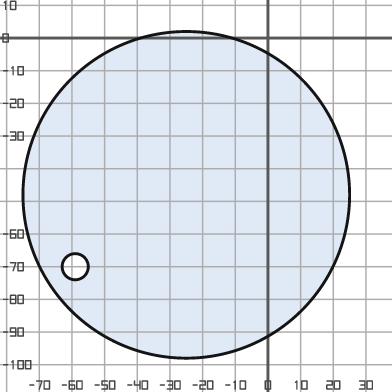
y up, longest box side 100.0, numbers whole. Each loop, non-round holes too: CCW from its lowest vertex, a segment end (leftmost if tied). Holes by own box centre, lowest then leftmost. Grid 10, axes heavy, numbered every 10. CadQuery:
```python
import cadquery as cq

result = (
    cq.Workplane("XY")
    .moveTo(-25.0, -48.0)
    .circle(50.0)
    .moveTo(-59.0, -70.0)
    .circle(4.0)
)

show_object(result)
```